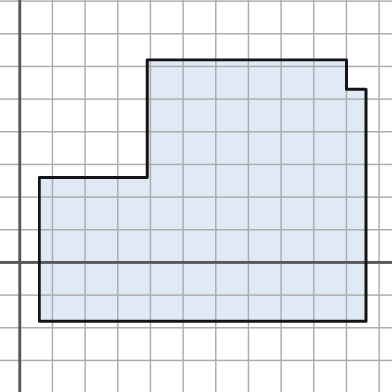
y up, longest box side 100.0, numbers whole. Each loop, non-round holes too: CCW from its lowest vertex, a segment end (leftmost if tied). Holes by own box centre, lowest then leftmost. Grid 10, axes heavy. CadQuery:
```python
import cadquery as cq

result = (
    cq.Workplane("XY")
    .moveTo(6.0, -18.0)
    .lineTo(106.0, -18.0)
    .lineTo(106.0, 53.0)
    .lineTo(100.0, 53.0)
    .lineTo(100.0, 62.0)
    .lineTo(39.0, 62.0)
    .lineTo(39.0, 26.0)
    .lineTo(6.0, 26.0)
    .close()
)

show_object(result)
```